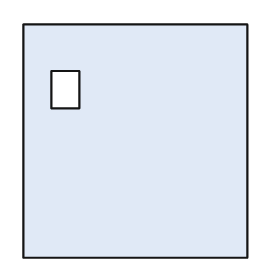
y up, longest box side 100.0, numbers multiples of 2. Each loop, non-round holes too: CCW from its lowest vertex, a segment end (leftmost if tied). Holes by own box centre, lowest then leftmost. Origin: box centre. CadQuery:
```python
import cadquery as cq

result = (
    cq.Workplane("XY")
    .moveTo(-48.0, -50.0)
    .lineTo(48.0, -50.0)
    .lineTo(48.0, 50.0)
    .lineTo(-48.0, 50.0)
    .close()
    .moveTo(-36.0, 14.0)
    .lineTo(-24.0, 14.0)
    .lineTo(-24.0, 30.0)
    .lineTo(-36.0, 30.0)
    .close()
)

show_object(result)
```